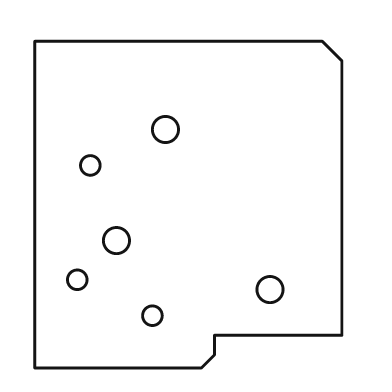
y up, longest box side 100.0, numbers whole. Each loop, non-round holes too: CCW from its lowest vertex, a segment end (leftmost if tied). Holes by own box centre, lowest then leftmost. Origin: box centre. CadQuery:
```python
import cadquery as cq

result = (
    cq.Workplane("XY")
    .moveTo(-47.0, -50.0)
    .lineTo(4.0, -50.0)
    .lineTo(8.0, -46.0)
    .lineTo(8.0, -40.0)
    .lineTo(47.0, -40.0)
    .lineTo(47.0, 44.0)
    .lineTo(41.0, 50.0)
    .lineTo(-47.0, 50.0)
    .close()
    .moveTo(-11.0, -34.0)
    .circle(3.0)
    .moveTo(25.0, -26.0)
    .circle(4.0)
    .moveTo(-34.0, -23.0)
    .circle(3.0)
    .moveTo(-22.0, -11.0)
    .circle(4.0)
    .moveTo(-30.0, 12.0)
    .circle(3.0)
    .moveTo(-7.0, 23.0)
    .circle(4.0)
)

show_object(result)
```